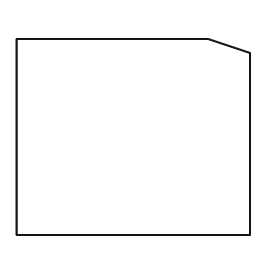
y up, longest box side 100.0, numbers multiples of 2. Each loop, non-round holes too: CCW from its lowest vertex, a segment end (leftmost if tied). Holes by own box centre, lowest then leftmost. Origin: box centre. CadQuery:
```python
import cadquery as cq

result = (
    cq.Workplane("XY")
    .moveTo(-50.0, -42.0)
    .lineTo(50.0, -42.0)
    .lineTo(50.0, 36.0)
    .lineTo(32.0, 42.0)
    .lineTo(-50.0, 42.0)
    .close()
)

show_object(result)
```